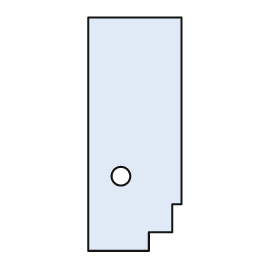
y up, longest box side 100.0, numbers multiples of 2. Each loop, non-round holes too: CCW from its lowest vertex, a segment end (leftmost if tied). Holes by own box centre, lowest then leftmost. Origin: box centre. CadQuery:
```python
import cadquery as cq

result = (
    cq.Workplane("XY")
    .moveTo(-20.0, -50.0)
    .lineTo(6.0, -50.0)
    .lineTo(6.0, -42.0)
    .lineTo(16.0, -42.0)
    .lineTo(16.0, -30.0)
    .lineTo(20.0, -30.0)
    .lineTo(20.0, 50.0)
    .lineTo(-20.0, 50.0)
    .close()
    .moveTo(-6.0, -18.0)
    .circle(4.0)
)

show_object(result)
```